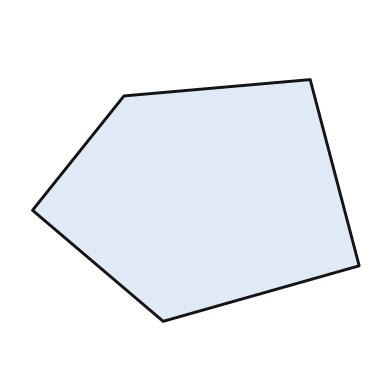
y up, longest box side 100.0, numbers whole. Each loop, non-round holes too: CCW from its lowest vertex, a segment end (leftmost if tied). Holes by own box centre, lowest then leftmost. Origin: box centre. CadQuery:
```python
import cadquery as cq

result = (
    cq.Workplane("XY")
    .moveTo(-10.0, -37.0)
    .lineTo(50.0, -20.0)
    .lineTo(35.0, 37.0)
    .lineTo(-22.0, 32.0)
    .lineTo(-50.0, -3.0)
    .close()
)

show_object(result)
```